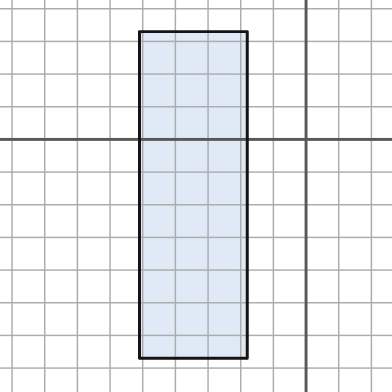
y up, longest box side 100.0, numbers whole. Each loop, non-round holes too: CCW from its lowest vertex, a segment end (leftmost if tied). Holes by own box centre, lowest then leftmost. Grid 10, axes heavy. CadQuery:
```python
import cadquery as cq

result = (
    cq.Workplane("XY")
    .moveTo(-51.0, -67.0)
    .lineTo(-18.0, -67.0)
    .lineTo(-18.0, 33.0)
    .lineTo(-51.0, 33.0)
    .close()
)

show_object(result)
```